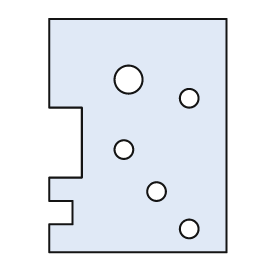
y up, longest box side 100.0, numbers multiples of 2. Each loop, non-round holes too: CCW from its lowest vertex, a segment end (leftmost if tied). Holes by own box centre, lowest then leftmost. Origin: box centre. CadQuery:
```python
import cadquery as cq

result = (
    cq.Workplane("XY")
    .moveTo(-38.0, -50.0)
    .lineTo(38.0, -50.0)
    .lineTo(38.0, 50.0)
    .lineTo(-38.0, 50.0)
    .lineTo(-38.0, 12.0)
    .lineTo(-24.0, 12.0)
    .lineTo(-24.0, -18.0)
    .lineTo(-38.0, -18.0)
    .lineTo(-38.0, -28.0)
    .lineTo(-28.0, -28.0)
    .lineTo(-28.0, -38.0)
    .lineTo(-38.0, -38.0)
    .close()
    .moveTo(22.0, -40.0)
    .circle(4.0)
    .moveTo(8.0, -24.0)
    .circle(4.0)
    .moveTo(-6.0, -6.0)
    .circle(4.0)
    .moveTo(22.0, 16.0)
    .circle(4.0)
    .moveTo(-4.0, 24.0)
    .circle(6.0)
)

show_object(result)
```